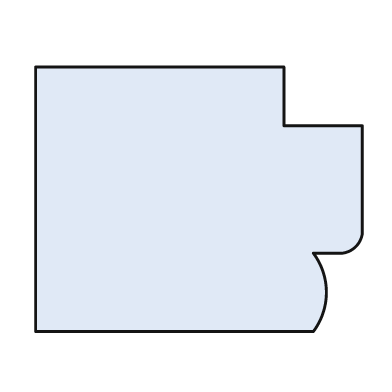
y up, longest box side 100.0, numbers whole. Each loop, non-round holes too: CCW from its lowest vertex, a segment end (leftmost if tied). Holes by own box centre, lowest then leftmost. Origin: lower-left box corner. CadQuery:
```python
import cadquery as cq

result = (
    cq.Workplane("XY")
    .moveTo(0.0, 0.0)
    .lineTo(85.0, 0.0)
    .threePointArc((89.0, 12.0), (85.0, 24.0))
    .lineTo(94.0, 24.0)
    .threePointArc((98.0, 26.0), (100.0, 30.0))
    .lineTo(100.0, 63.0)
    .lineTo(76.0, 63.0)
    .lineTo(76.0, 81.0)
    .lineTo(0.0, 81.0)
    .close()
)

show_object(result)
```